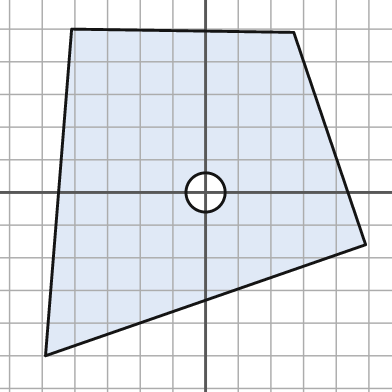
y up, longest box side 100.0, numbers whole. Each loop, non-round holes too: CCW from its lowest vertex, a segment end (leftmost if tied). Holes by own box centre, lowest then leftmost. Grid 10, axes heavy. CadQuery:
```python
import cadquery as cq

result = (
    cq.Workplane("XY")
    .moveTo(-49.0, -50.0)
    .lineTo(49.0, -16.0)
    .lineTo(27.0, 49.0)
    .lineTo(-41.0, 50.0)
    .close()
    .moveTo(0.0, 0.0)
    .circle(6.0)
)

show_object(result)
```